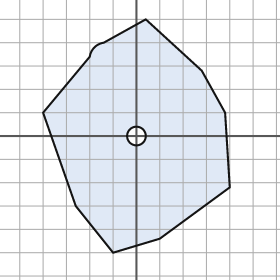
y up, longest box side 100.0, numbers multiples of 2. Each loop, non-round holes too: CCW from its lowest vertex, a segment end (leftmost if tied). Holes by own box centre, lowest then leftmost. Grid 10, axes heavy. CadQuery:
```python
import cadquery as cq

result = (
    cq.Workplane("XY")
    .moveTo(-10.0, -50.0)
    .lineTo(10.0, -44.0)
    .lineTo(40.0, -22.0)
    .lineTo(38.0, 10.0)
    .lineTo(28.0, 28.0)
    .lineTo(4.0, 50.0)
    .lineTo(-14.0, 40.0)
    .threePointArc((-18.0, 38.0), (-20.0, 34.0))
    .lineTo(-40.0, 10.0)
    .lineTo(-26.0, -30.0)
    .close()
    .moveTo(0.0, 0.0)
    .circle(4.0)
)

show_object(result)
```